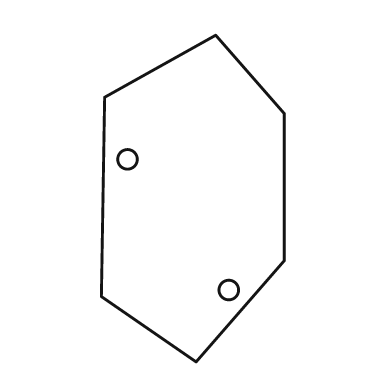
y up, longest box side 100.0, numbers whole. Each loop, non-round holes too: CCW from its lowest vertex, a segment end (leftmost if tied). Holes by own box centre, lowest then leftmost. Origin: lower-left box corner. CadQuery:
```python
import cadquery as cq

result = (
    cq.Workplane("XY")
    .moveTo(29.0, 0.0)
    .lineTo(56.0, 31.0)
    .lineTo(56.0, 76.0)
    .lineTo(35.0, 100.0)
    .lineTo(1.0, 81.0)
    .lineTo(0.0, 20.0)
    .close()
    .moveTo(39.0, 22.0)
    .circle(3.0)
    .moveTo(8.0, 62.0)
    .circle(3.0)
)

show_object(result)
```